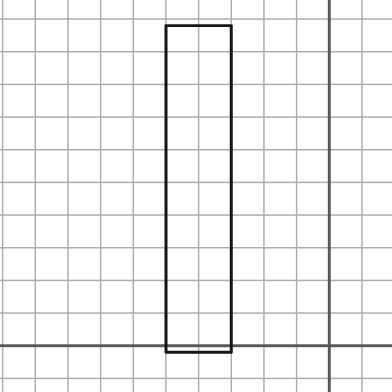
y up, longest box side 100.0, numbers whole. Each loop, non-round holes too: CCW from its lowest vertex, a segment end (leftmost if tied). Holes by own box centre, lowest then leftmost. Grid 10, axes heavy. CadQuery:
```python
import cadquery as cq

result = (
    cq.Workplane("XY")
    .moveTo(-50.0, -2.0)
    .lineTo(-30.0, -2.0)
    .lineTo(-30.0, 98.0)
    .lineTo(-50.0, 98.0)
    .close()
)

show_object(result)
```